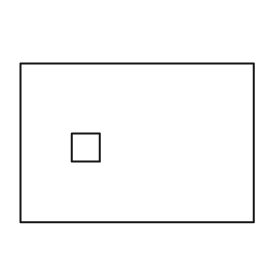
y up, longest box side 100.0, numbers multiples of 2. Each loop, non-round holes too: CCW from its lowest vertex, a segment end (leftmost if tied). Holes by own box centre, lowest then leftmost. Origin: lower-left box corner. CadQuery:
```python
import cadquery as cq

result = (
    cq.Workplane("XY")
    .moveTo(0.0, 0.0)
    .lineTo(100.0, 0.0)
    .lineTo(100.0, 68.0)
    .lineTo(0.0, 68.0)
    .close()
    .moveTo(22.0, 26.0)
    .lineTo(34.0, 26.0)
    .lineTo(34.0, 38.0)
    .lineTo(22.0, 38.0)
    .close()
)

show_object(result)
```